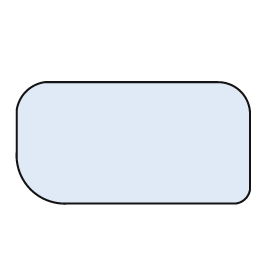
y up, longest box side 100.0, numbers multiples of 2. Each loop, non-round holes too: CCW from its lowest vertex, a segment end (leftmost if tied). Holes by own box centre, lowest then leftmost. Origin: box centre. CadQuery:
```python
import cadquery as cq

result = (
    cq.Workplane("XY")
    .moveTo(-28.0, -26.0)
    .lineTo(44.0, -26.0)
    .threePointArc((48.0, -24.0), (50.0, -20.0))
    .lineTo(50.0, 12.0)
    .threePointArc((46.0, 22.0), (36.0, 26.0))
    .lineTo(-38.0, 26.0)
    .threePointArc((-46.0, 22.0), (-50.0, 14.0))
    .lineTo(-50.0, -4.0)
    .threePointArc((-44.0, -20.0), (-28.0, -26.0))
    .close()
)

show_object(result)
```